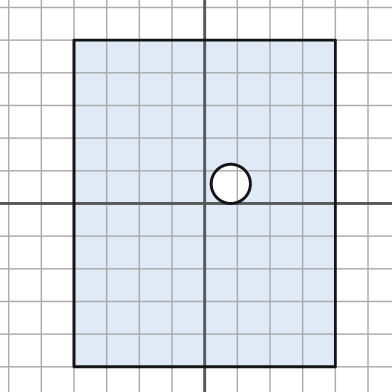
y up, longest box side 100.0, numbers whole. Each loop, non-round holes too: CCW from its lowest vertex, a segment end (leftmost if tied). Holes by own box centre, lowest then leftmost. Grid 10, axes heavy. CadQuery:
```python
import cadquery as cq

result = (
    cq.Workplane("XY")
    .moveTo(-40.0, -50.0)
    .lineTo(40.0, -50.0)
    .lineTo(40.0, 50.0)
    .lineTo(-40.0, 50.0)
    .close()
    .moveTo(8.0, 6.0)
    .circle(6.0)
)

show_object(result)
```